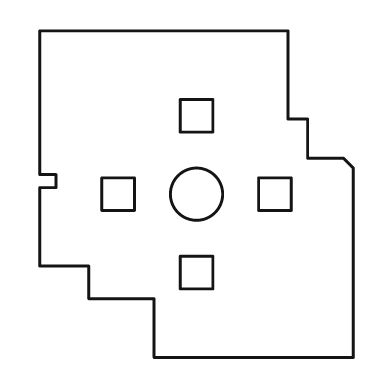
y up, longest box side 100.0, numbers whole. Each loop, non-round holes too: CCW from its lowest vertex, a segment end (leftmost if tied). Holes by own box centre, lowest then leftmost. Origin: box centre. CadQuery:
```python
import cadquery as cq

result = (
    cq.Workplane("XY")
    .moveTo(-13.0, -50.0)
    .lineTo(48.0, -50.0)
    .lineTo(48.0, 8.0)
    .lineTo(45.0, 11.0)
    .lineTo(34.0, 11.0)
    .lineTo(34.0, 23.0)
    .lineTo(28.0, 23.0)
    .lineTo(28.0, 50.0)
    .lineTo(-48.0, 50.0)
    .lineTo(-48.0, 6.0)
    .lineTo(-43.0, 6.0)
    .lineTo(-43.0, 2.0)
    .lineTo(-48.0, 2.0)
    .lineTo(-48.0, -22.0)
    .lineTo(-33.0, -22.0)
    .lineTo(-33.0, -32.0)
    .lineTo(-13.0, -32.0)
    .close()
    .moveTo(-5.0, -29.0)
    .lineTo(5.0, -29.0)
    .lineTo(5.0, -19.0)
    .lineTo(-5.0, -19.0)
    .close()
    .moveTo(-29.0, -5.0)
    .lineTo(-19.0, -5.0)
    .lineTo(-19.0, 5.0)
    .lineTo(-29.0, 5.0)
    .close()
    .moveTo(0.0, 0.0)
    .circle(8.0)
    .moveTo(19.0, -5.0)
    .lineTo(29.0, -5.0)
    .lineTo(29.0, 5.0)
    .lineTo(19.0, 5.0)
    .close()
    .moveTo(-5.0, 19.0)
    .lineTo(5.0, 19.0)
    .lineTo(5.0, 29.0)
    .lineTo(-5.0, 29.0)
    .close()
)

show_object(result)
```